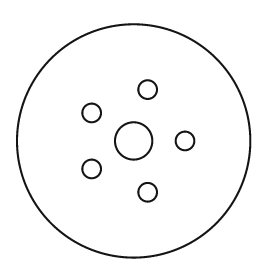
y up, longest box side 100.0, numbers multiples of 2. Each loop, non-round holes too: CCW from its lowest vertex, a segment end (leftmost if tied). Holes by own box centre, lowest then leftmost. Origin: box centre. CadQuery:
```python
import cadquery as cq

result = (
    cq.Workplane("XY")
    .moveTo(0.0, 0.0)
    .circle(50.0)
    .moveTo(6.0, -22.0)
    .circle(4.0)
    .moveTo(-18.0, -12.0)
    .circle(4.0)
    .moveTo(0.0, 0.0)
    .circle(8.0)
    .moveTo(22.0, 0.0)
    .circle(4.0)
    .moveTo(-18.0, 12.0)
    .circle(4.0)
    .moveTo(6.0, 22.0)
    .circle(4.0)
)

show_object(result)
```